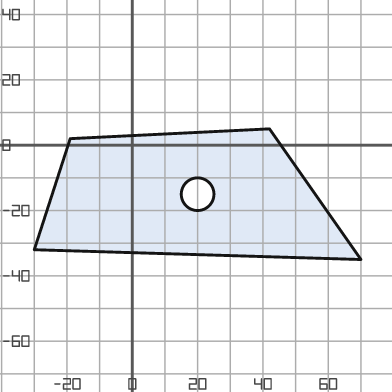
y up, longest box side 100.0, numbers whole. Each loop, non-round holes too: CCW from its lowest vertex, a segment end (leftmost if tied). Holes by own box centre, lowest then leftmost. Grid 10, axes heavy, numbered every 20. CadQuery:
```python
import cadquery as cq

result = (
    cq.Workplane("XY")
    .moveTo(70.0, -35.0)
    .lineTo(42.0, 5.0)
    .lineTo(-19.0, 2.0)
    .lineTo(-30.0, -32.0)
    .close()
    .moveTo(20.0, -15.0)
    .circle(5.0)
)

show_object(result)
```